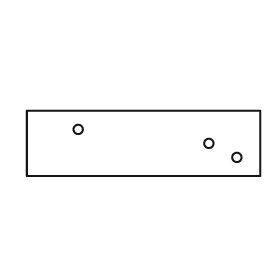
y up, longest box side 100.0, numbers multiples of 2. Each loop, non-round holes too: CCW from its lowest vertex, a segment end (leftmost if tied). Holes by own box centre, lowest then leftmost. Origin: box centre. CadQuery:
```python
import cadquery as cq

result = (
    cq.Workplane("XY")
    .moveTo(-50.0, -14.0)
    .lineTo(50.0, -14.0)
    .lineTo(50.0, 14.0)
    .lineTo(-50.0, 14.0)
    .close()
    .moveTo(40.0, -6.0)
    .circle(2.0)
    .moveTo(28.0, 0.0)
    .circle(2.0)
    .moveTo(-28.0, 6.0)
    .circle(2.0)
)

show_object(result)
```